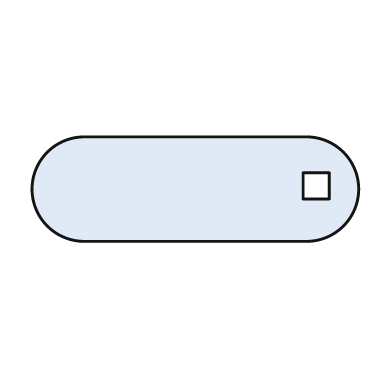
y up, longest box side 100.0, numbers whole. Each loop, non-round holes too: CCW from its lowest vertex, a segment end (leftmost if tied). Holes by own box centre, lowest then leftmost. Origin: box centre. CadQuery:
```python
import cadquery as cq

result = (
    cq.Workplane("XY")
    .moveTo(-34.0, -16.0)
    .lineTo(34.0, -16.0)
    .threePointArc((50.0, 0.0), (34.0, 16.0))
    .lineTo(-34.0, 16.0)
    .threePointArc((-50.0, 0.0), (-34.0, -16.0))
    .close()
    .moveTo(33.0, -3.0)
    .lineTo(41.0, -3.0)
    .lineTo(41.0, 5.0)
    .lineTo(33.0, 5.0)
    .close()
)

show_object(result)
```